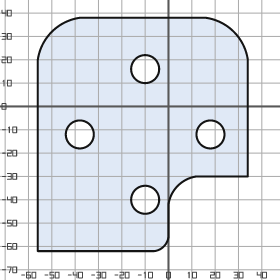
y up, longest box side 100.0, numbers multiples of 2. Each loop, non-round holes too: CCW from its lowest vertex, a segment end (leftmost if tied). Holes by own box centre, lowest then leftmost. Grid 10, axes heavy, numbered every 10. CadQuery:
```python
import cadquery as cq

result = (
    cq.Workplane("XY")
    .moveTo(-56.0, -62.0)
    .lineTo(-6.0, -62.0)
    .threePointArc((-2.0, -60.0), (0.0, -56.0))
    .lineTo(0.0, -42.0)
    .threePointArc((4.0, -34.0), (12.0, -30.0))
    .lineTo(34.0, -30.0)
    .lineTo(34.0, 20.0)
    .threePointArc((28.0, 32.0), (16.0, 38.0))
    .lineTo(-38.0, 38.0)
    .threePointArc((-50.0, 32.0), (-56.0, 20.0))
    .close()
    .moveTo(-10.0, -40.0)
    .circle(6.0)
    .moveTo(-38.0, -12.0)
    .circle(6.0)
    .moveTo(18.0, -12.0)
    .circle(6.0)
    .moveTo(-10.0, 16.0)
    .circle(6.0)
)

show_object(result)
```